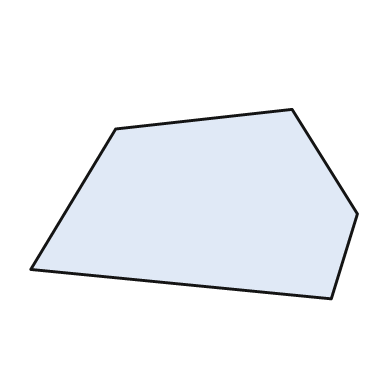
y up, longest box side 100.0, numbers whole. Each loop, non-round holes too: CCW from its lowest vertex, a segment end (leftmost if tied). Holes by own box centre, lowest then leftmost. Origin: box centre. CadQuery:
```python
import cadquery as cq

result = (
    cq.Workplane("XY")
    .moveTo(42.0, -29.0)
    .lineTo(50.0, -3.0)
    .lineTo(30.0, 29.0)
    .lineTo(-24.0, 23.0)
    .lineTo(-50.0, -20.0)
    .close()
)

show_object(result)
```